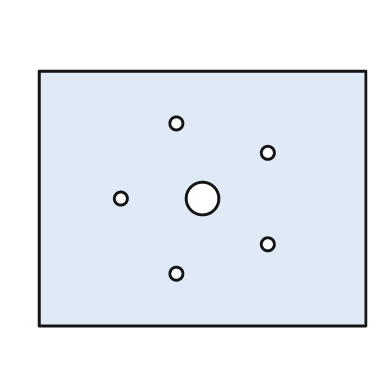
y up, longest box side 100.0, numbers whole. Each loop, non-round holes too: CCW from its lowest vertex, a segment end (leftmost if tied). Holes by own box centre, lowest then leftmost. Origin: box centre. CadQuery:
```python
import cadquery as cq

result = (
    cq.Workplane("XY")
    .moveTo(-50.0, -39.0)
    .lineTo(50.0, -39.0)
    .lineTo(50.0, 39.0)
    .lineTo(-50.0, 39.0)
    .close()
    .moveTo(-8.0, -23.0)
    .circle(2.0)
    .moveTo(20.0, -14.0)
    .circle(2.0)
    .moveTo(-25.0, 0.0)
    .circle(2.0)
    .moveTo(0.0, 0.0)
    .circle(5.0)
    .moveTo(20.0, 14.0)
    .circle(2.0)
    .moveTo(-8.0, 23.0)
    .circle(2.0)
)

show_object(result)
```